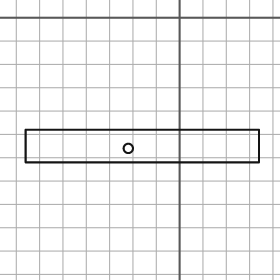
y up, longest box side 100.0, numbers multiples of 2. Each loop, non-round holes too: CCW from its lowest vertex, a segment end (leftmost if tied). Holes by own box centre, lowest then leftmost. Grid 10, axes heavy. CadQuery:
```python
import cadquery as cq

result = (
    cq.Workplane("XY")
    .moveTo(-66.0, -62.0)
    .lineTo(34.0, -62.0)
    .lineTo(34.0, -48.0)
    .lineTo(-66.0, -48.0)
    .close()
    .moveTo(-22.0, -56.0)
    .circle(2.0)
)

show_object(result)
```